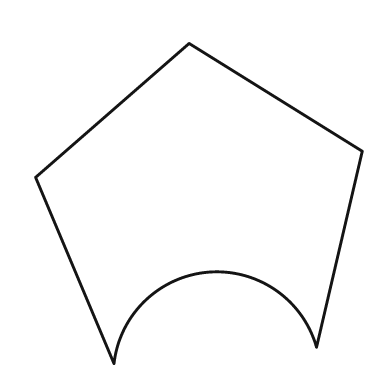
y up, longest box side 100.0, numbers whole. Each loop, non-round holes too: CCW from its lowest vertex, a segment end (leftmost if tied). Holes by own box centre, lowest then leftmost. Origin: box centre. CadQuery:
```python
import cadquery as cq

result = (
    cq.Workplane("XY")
    .moveTo(-26.0, -49.0)
    .threePointArc((3.0, -21.0), (36.0, -44.0))
    .lineTo(50.0, 16.0)
    .lineTo(-3.0, 49.0)
    .lineTo(-50.0, 8.0)
    .close()
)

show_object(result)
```